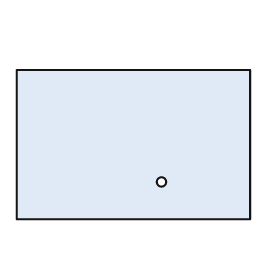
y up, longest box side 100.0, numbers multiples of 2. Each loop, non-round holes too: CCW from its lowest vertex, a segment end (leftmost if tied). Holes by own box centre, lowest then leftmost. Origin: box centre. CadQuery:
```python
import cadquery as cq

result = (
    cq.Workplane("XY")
    .moveTo(-50.0, -32.0)
    .lineTo(50.0, -32.0)
    .lineTo(50.0, 32.0)
    .lineTo(-50.0, 32.0)
    .close()
    .moveTo(12.0, -16.0)
    .circle(2.0)
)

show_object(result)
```